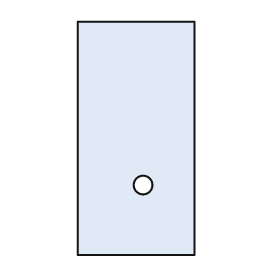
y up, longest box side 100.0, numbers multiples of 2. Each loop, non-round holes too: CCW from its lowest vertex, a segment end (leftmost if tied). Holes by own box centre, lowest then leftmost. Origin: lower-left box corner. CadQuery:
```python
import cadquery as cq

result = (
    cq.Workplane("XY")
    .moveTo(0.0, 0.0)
    .lineTo(50.0, 0.0)
    .lineTo(50.0, 100.0)
    .lineTo(0.0, 100.0)
    .close()
    .moveTo(28.0, 30.0)
    .circle(4.0)
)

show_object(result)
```